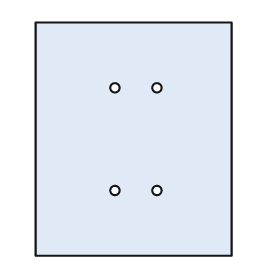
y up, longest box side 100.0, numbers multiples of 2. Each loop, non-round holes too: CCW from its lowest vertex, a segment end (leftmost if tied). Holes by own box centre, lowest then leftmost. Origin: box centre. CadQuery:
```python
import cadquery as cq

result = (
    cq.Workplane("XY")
    .moveTo(-42.0, -50.0)
    .lineTo(42.0, -50.0)
    .lineTo(42.0, 50.0)
    .lineTo(-42.0, 50.0)
    .close()
    .moveTo(-8.0, -22.0)
    .circle(2.0)
    .moveTo(10.0, -22.0)
    .circle(2.0)
    .moveTo(-8.0, 22.0)
    .circle(2.0)
    .moveTo(10.0, 22.0)
    .circle(2.0)
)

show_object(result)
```